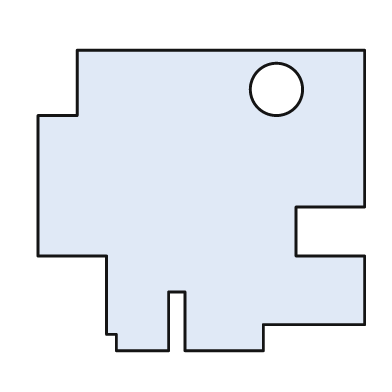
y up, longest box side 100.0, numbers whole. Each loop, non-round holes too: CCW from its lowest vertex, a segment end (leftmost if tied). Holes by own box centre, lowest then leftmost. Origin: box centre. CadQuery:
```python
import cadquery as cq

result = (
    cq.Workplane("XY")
    .moveTo(-26.0, -46.0)
    .lineTo(-10.0, -46.0)
    .lineTo(-10.0, -28.0)
    .lineTo(-5.0, -28.0)
    .lineTo(-5.0, -46.0)
    .lineTo(19.0, -46.0)
    .lineTo(19.0, -38.0)
    .lineTo(50.0, -38.0)
    .lineTo(50.0, -17.0)
    .lineTo(29.0, -17.0)
    .lineTo(29.0, -2.0)
    .lineTo(50.0, -2.0)
    .lineTo(50.0, 46.0)
    .lineTo(-38.0, 46.0)
    .lineTo(-38.0, 26.0)
    .lineTo(-50.0, 26.0)
    .lineTo(-50.0, -17.0)
    .lineTo(-29.0, -17.0)
    .lineTo(-29.0, -41.0)
    .lineTo(-26.0, -41.0)
    .close()
    .moveTo(23.0, 34.0)
    .circle(8.0)
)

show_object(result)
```